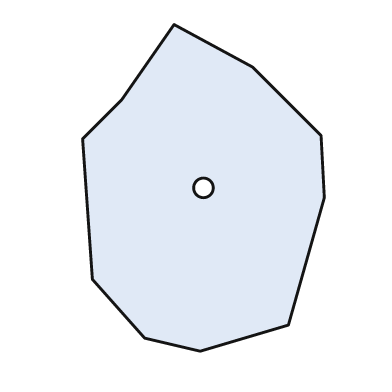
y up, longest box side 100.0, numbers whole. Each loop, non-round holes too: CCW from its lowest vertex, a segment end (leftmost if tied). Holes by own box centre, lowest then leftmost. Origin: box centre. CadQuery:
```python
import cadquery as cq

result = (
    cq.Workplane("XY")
    .moveTo(-1.0, -50.0)
    .lineTo(26.0, -42.0)
    .lineTo(37.0, -3.0)
    .lineTo(36.0, 16.0)
    .lineTo(15.0, 37.0)
    .lineTo(-9.0, 50.0)
    .lineTo(-25.0, 27.0)
    .lineTo(-37.0, 15.0)
    .lineTo(-34.0, -28.0)
    .lineTo(-18.0, -46.0)
    .close()
    .moveTo(0.0, 0.0)
    .circle(3.0)
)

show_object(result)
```